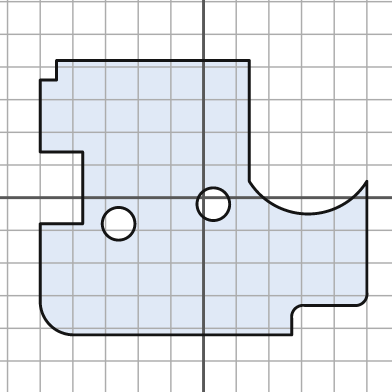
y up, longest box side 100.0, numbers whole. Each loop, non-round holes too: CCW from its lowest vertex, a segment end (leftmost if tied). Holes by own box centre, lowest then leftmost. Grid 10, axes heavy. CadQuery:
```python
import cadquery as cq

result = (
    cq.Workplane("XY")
    .moveTo(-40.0, -42.0)
    .lineTo(27.0, -42.0)
    .lineTo(27.0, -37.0)
    .threePointArc((28.0, -34.0), (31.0, -33.0))
    .lineTo(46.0, -33.0)
    .threePointArc((49.0, -32.0), (50.0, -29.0))
    .lineTo(50.0, 5.0)
    .threePointArc((32.0, -5.0), (14.0, 5.0))
    .lineTo(14.0, 42.0)
    .lineTo(-45.0, 42.0)
    .lineTo(-45.0, 36.0)
    .lineTo(-50.0, 36.0)
    .lineTo(-50.0, 14.0)
    .lineTo(-37.0, 14.0)
    .lineTo(-37.0, -8.0)
    .lineTo(-50.0, -8.0)
    .lineTo(-50.0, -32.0)
    .threePointArc((-47.0, -39.0), (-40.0, -42.0))
    .close()
    .moveTo(-26.0, -8.0)
    .circle(5.0)
    .moveTo(3.0, -2.0)
    .circle(5.0)
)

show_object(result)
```